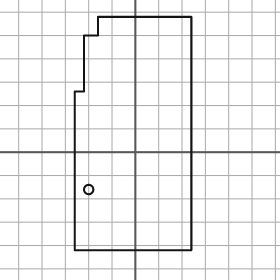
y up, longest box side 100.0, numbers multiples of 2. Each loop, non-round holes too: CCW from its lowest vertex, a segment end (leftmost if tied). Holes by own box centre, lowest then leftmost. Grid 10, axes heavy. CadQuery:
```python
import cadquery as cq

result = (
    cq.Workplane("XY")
    .moveTo(-26.0, -42.0)
    .lineTo(24.0, -42.0)
    .lineTo(24.0, 58.0)
    .lineTo(-16.0, 58.0)
    .lineTo(-16.0, 50.0)
    .lineTo(-22.0, 50.0)
    .lineTo(-22.0, 26.0)
    .lineTo(-26.0, 26.0)
    .close()
    .moveTo(-20.0, -16.0)
    .circle(2.0)
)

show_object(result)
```